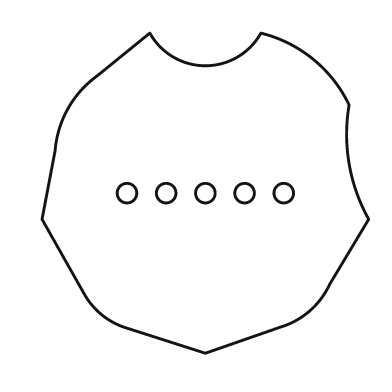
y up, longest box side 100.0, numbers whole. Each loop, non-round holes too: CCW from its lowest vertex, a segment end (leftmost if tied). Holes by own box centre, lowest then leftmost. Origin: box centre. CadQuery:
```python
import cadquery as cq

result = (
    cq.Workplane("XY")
    .moveTo(0.0, -49.0)
    .lineTo(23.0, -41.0)
    .threePointArc((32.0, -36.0), (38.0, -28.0))
    .lineTo(50.0, -8.0)
    .threePointArc((44.0, 9.0), (44.0, 27.0))
    .threePointArc((33.0, 41.0), (17.0, 49.0))
    .threePointArc((0.0, 39.0), (-17.0, 49.0))
    .lineTo(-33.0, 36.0)
    .threePointArc((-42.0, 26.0), (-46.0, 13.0))
    .lineTo(-50.0, -8.0)
    .lineTo(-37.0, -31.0)
    .threePointArc((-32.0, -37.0), (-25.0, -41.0))
    .close()
    .moveTo(-24.0, 0.0)
    .circle(3.0)
    .moveTo(-12.0, 0.0)
    .circle(3.0)
    .moveTo(0.0, 0.0)
    .circle(3.0)
    .moveTo(12.0, 0.0)
    .circle(3.0)
    .moveTo(24.0, 0.0)
    .circle(3.0)
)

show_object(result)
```